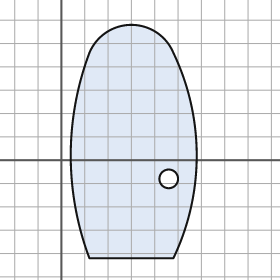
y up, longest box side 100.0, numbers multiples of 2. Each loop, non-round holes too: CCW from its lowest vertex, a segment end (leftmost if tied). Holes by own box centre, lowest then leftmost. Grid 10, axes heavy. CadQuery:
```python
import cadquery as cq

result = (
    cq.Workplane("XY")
    .moveTo(12.0, -42.0)
    .lineTo(48.0, -42.0)
    .threePointArc((58.0, 2.0), (48.0, 46.0))
    .threePointArc((30.0, 58.0), (12.0, 46.0))
    .threePointArc((4.0, 2.0), (12.0, -42.0))
    .close()
    .moveTo(46.0, -8.0)
    .circle(4.0)
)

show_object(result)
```